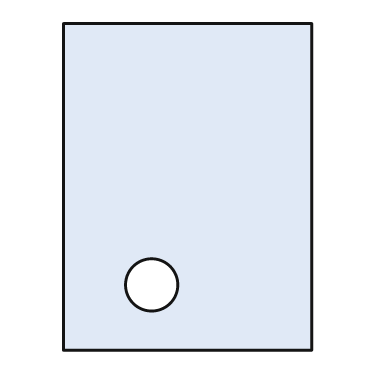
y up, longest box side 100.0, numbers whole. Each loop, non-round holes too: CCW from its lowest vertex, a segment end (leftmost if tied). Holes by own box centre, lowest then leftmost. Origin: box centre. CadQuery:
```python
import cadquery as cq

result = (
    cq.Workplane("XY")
    .moveTo(-38.0, -50.0)
    .lineTo(38.0, -50.0)
    .lineTo(38.0, 50.0)
    .lineTo(-38.0, 50.0)
    .close()
    .moveTo(-11.0, -30.0)
    .circle(8.0)
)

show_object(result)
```